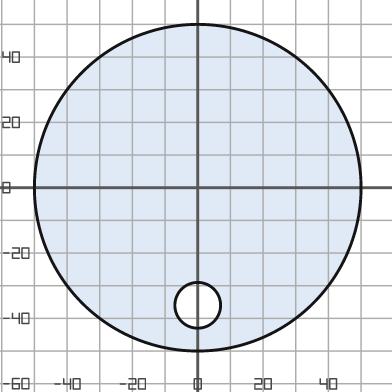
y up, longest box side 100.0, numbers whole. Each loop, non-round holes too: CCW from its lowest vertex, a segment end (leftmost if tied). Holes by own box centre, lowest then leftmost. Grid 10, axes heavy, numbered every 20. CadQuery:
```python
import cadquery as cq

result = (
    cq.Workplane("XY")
    .moveTo(0.0, 0.0)
    .circle(50.0)
    .moveTo(0.0, -36.0)
    .circle(7.0)
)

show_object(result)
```